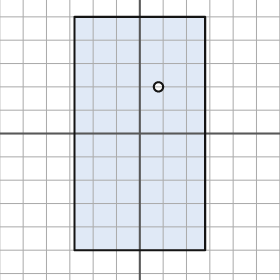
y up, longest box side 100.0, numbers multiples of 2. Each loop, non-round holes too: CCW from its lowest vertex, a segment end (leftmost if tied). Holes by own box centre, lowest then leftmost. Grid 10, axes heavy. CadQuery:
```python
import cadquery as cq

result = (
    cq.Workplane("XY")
    .moveTo(-28.0, -50.0)
    .lineTo(28.0, -50.0)
    .lineTo(28.0, 50.0)
    .lineTo(-28.0, 50.0)
    .close()
    .moveTo(8.0, 20.0)
    .circle(2.0)
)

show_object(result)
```